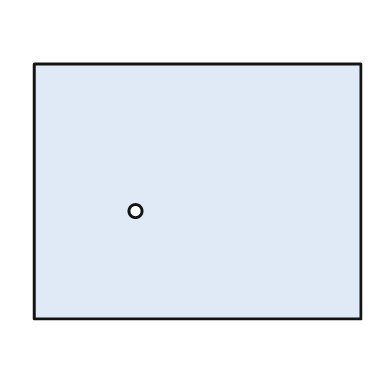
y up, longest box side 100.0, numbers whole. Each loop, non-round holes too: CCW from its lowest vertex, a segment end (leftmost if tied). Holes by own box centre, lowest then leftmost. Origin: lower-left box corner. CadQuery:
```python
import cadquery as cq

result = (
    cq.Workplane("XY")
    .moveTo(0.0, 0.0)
    .lineTo(100.0, 0.0)
    .lineTo(100.0, 78.0)
    .lineTo(0.0, 78.0)
    .close()
    .moveTo(31.0, 33.0)
    .circle(2.0)
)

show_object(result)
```